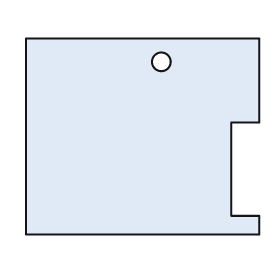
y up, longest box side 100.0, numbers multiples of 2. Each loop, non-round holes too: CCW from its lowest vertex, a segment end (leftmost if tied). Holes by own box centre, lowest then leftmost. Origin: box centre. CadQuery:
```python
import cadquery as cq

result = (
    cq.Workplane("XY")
    .moveTo(-50.0, -42.0)
    .lineTo(50.0, -42.0)
    .lineTo(50.0, -34.0)
    .lineTo(38.0, -34.0)
    .lineTo(38.0, 6.0)
    .lineTo(50.0, 6.0)
    .lineTo(50.0, 42.0)
    .lineTo(-50.0, 42.0)
    .close()
    .moveTo(8.0, 32.0)
    .circle(4.0)
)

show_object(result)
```